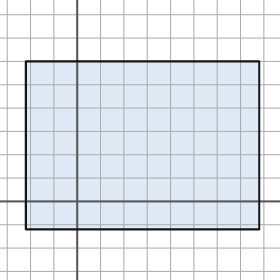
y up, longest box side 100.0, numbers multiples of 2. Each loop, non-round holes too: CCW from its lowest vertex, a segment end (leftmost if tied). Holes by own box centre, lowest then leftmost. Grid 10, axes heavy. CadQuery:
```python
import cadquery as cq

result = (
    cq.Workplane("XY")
    .moveTo(-22.0, -12.0)
    .lineTo(78.0, -12.0)
    .lineTo(78.0, 60.0)
    .lineTo(-22.0, 60.0)
    .close()
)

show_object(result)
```